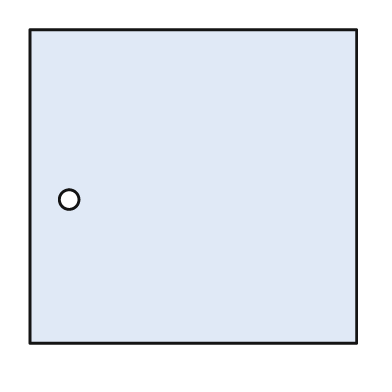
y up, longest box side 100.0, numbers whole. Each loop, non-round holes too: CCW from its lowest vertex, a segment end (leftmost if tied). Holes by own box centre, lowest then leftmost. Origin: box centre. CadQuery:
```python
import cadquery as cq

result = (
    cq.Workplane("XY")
    .moveTo(-50.0, -48.0)
    .lineTo(50.0, -48.0)
    .lineTo(50.0, 48.0)
    .lineTo(-50.0, 48.0)
    .close()
    .moveTo(-38.0, -4.0)
    .circle(3.0)
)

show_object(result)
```